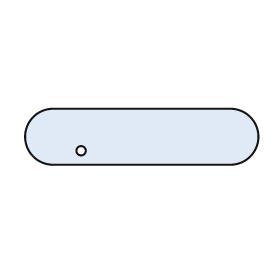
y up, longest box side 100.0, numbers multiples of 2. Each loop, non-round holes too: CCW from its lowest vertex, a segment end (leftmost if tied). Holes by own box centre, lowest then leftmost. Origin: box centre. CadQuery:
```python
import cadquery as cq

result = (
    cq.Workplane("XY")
    .moveTo(-38.0, -12.0)
    .lineTo(38.0, -12.0)
    .threePointArc((50.0, 0.0), (38.0, 12.0))
    .lineTo(-38.0, 12.0)
    .threePointArc((-50.0, 0.0), (-38.0, -12.0))
    .close()
    .moveTo(-26.0, -6.0)
    .circle(2.0)
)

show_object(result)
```